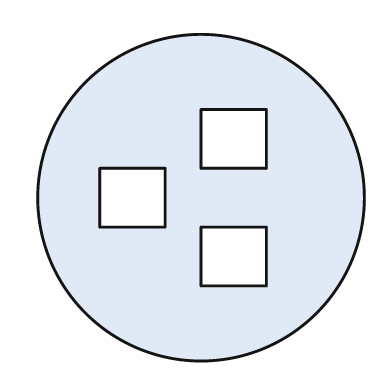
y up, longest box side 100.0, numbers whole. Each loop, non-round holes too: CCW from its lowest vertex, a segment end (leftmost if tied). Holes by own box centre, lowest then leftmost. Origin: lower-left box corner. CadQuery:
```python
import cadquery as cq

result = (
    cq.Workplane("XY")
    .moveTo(50.0, 50.0)
    .circle(50.0)
    .moveTo(50.0, 23.0)
    .lineTo(70.0, 23.0)
    .lineTo(70.0, 41.0)
    .lineTo(50.0, 41.0)
    .close()
    .moveTo(19.0, 41.0)
    .lineTo(39.0, 41.0)
    .lineTo(39.0, 59.0)
    .lineTo(19.0, 59.0)
    .close()
    .moveTo(50.0, 59.0)
    .lineTo(70.0, 59.0)
    .lineTo(70.0, 77.0)
    .lineTo(50.0, 77.0)
    .close()
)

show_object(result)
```